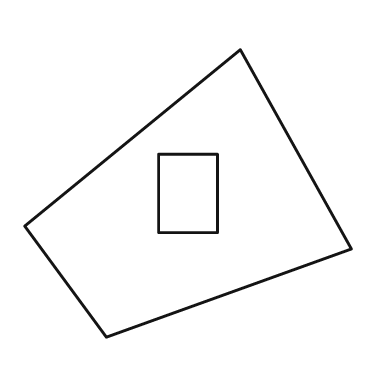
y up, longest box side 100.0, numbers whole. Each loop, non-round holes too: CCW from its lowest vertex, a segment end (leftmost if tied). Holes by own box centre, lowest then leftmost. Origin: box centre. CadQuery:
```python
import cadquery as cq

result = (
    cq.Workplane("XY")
    .moveTo(-25.0, -44.0)
    .lineTo(50.0, -17.0)
    .lineTo(16.0, 44.0)
    .lineTo(-50.0, -10.0)
    .close()
    .moveTo(-9.0, -12.0)
    .lineTo(9.0, -12.0)
    .lineTo(9.0, 12.0)
    .lineTo(-9.0, 12.0)
    .close()
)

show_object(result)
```